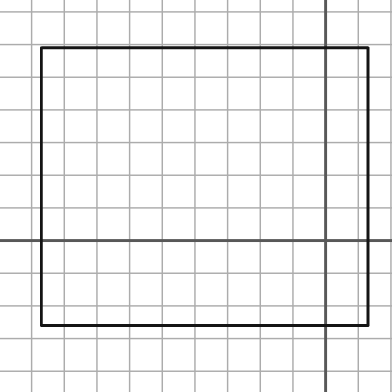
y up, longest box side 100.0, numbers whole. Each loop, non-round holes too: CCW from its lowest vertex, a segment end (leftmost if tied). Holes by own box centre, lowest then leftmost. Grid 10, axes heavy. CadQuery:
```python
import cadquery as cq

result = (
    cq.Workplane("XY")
    .moveTo(-87.0, -26.0)
    .lineTo(13.0, -26.0)
    .lineTo(13.0, 59.0)
    .lineTo(-87.0, 59.0)
    .close()
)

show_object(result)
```